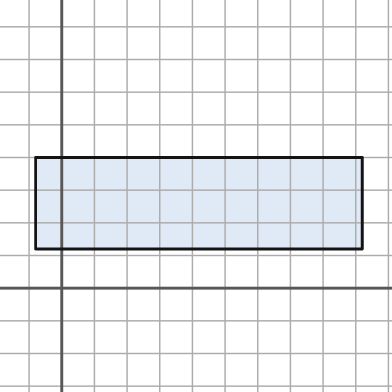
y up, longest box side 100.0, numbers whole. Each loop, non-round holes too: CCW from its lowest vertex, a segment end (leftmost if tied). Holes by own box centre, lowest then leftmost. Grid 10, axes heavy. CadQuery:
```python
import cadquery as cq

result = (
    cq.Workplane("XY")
    .moveTo(-8.0, 12.0)
    .lineTo(92.0, 12.0)
    .lineTo(92.0, 40.0)
    .lineTo(-8.0, 40.0)
    .close()
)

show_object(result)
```